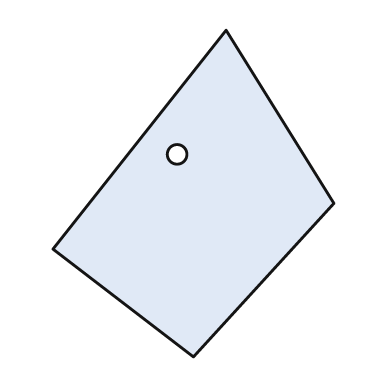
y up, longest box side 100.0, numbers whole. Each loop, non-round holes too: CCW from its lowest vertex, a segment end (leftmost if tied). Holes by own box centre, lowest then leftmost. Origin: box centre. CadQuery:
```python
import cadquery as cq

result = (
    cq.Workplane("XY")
    .moveTo(0.0, -50.0)
    .lineTo(43.0, -3.0)
    .lineTo(10.0, 50.0)
    .lineTo(-43.0, -17.0)
    .close()
    .moveTo(-5.0, 12.0)
    .circle(3.0)
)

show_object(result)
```